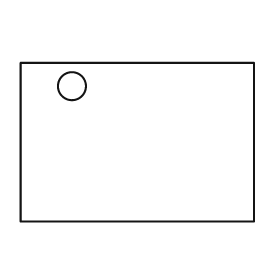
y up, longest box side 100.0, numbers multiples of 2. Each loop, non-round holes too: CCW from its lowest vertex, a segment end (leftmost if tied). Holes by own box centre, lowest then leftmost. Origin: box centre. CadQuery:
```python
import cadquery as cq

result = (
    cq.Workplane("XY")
    .moveTo(-50.0, -34.0)
    .lineTo(50.0, -34.0)
    .lineTo(50.0, 34.0)
    .lineTo(-50.0, 34.0)
    .close()
    .moveTo(-28.0, 24.0)
    .circle(6.0)
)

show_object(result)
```